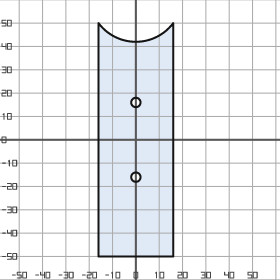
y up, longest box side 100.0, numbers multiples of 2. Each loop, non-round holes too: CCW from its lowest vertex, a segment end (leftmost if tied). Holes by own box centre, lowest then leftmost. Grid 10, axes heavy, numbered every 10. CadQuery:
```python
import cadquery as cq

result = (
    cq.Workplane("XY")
    .moveTo(-16.0, -50.0)
    .lineTo(16.0, -50.0)
    .lineTo(16.0, 50.0)
    .threePointArc((0.0, 42.0), (-16.0, 50.0))
    .close()
    .moveTo(0.0, -16.0)
    .circle(2.0)
    .moveTo(0.0, 16.0)
    .circle(2.0)
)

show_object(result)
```